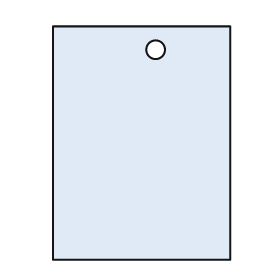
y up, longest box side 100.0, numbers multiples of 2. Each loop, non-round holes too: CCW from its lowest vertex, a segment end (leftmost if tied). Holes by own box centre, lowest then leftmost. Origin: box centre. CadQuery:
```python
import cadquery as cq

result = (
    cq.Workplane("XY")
    .moveTo(-38.0, -50.0)
    .lineTo(38.0, -50.0)
    .lineTo(38.0, 50.0)
    .lineTo(-38.0, 50.0)
    .close()
    .moveTo(6.0, 40.0)
    .circle(4.0)
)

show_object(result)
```